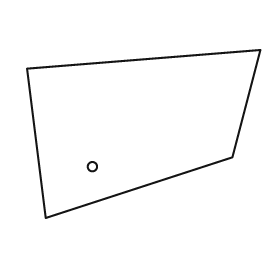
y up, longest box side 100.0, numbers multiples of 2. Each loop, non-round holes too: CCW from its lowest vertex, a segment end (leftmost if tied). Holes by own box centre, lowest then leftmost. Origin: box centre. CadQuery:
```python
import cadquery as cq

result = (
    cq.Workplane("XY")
    .moveTo(-42.0, -36.0)
    .lineTo(38.0, -10.0)
    .lineTo(50.0, 36.0)
    .lineTo(-50.0, 28.0)
    .close()
    .moveTo(-22.0, -14.0)
    .circle(2.0)
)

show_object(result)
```